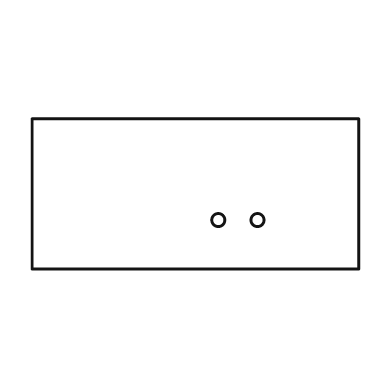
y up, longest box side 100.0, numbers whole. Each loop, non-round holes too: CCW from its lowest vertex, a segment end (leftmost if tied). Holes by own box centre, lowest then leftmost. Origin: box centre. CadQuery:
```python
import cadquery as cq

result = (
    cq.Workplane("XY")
    .moveTo(-50.0, -23.0)
    .lineTo(50.0, -23.0)
    .lineTo(50.0, 23.0)
    .lineTo(-50.0, 23.0)
    .close()
    .moveTo(7.0, -8.0)
    .circle(2.0)
    .moveTo(19.0, -8.0)
    .circle(2.0)
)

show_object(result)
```